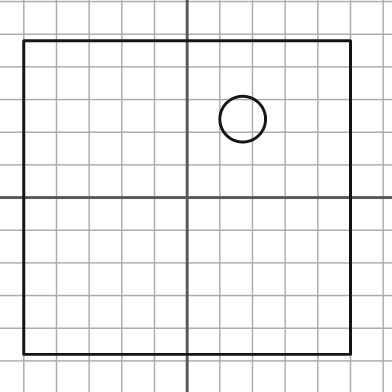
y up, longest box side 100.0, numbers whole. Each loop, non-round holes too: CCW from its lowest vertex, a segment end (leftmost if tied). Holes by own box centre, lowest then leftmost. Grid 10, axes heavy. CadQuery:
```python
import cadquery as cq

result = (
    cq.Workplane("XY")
    .moveTo(-50.0, -48.0)
    .lineTo(50.0, -48.0)
    .lineTo(50.0, 48.0)
    .lineTo(-50.0, 48.0)
    .close()
    .moveTo(17.0, 24.0)
    .circle(7.0)
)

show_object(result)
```